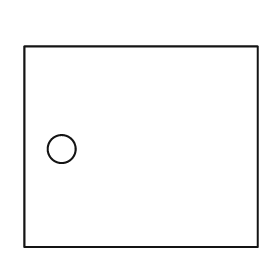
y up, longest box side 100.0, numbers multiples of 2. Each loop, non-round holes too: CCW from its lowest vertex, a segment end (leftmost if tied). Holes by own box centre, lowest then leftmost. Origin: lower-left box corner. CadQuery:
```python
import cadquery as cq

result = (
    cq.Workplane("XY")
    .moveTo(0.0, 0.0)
    .lineTo(100.0, 0.0)
    .lineTo(100.0, 86.0)
    .lineTo(0.0, 86.0)
    .close()
    .moveTo(16.0, 42.0)
    .circle(6.0)
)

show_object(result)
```